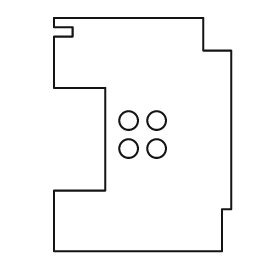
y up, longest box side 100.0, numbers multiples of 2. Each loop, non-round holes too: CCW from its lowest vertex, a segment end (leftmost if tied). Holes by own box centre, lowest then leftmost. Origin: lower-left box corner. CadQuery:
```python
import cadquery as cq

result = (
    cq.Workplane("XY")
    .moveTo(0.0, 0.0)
    .lineTo(72.0, 0.0)
    .lineTo(72.0, 18.0)
    .lineTo(76.0, 18.0)
    .lineTo(76.0, 86.0)
    .lineTo(64.0, 86.0)
    .lineTo(64.0, 100.0)
    .lineTo(0.0, 100.0)
    .lineTo(0.0, 96.0)
    .lineTo(8.0, 96.0)
    .lineTo(8.0, 92.0)
    .lineTo(0.0, 92.0)
    .lineTo(0.0, 70.0)
    .lineTo(22.0, 70.0)
    .lineTo(22.0, 26.0)
    .lineTo(0.0, 26.0)
    .close()
    .moveTo(32.0, 44.0)
    .circle(4.0)
    .moveTo(44.0, 44.0)
    .circle(4.0)
    .moveTo(32.0, 56.0)
    .circle(4.0)
    .moveTo(44.0, 56.0)
    .circle(4.0)
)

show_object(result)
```